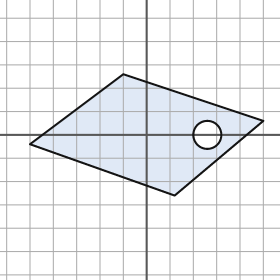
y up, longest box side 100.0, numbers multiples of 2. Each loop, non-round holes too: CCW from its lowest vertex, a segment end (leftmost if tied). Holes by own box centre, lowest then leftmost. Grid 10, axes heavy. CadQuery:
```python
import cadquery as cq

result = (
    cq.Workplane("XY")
    .moveTo(12.0, -26.0)
    .lineTo(50.0, 6.0)
    .lineTo(-10.0, 26.0)
    .lineTo(-50.0, -4.0)
    .close()
    .moveTo(26.0, 0.0)
    .circle(6.0)
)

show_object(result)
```